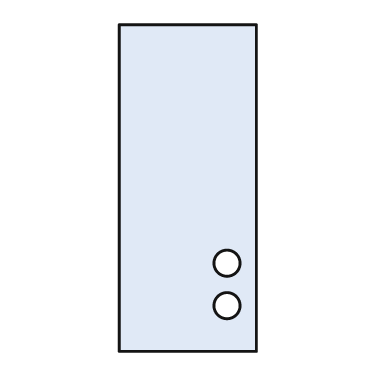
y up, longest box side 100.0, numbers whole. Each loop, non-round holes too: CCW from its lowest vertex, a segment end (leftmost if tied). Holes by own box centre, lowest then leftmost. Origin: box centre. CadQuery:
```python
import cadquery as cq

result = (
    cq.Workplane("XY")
    .moveTo(-21.0, -50.0)
    .lineTo(21.0, -50.0)
    .lineTo(21.0, 50.0)
    .lineTo(-21.0, 50.0)
    .close()
    .moveTo(12.0, -36.0)
    .circle(4.0)
    .moveTo(12.0, -23.0)
    .circle(4.0)
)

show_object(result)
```